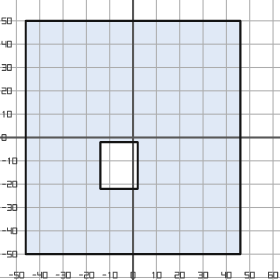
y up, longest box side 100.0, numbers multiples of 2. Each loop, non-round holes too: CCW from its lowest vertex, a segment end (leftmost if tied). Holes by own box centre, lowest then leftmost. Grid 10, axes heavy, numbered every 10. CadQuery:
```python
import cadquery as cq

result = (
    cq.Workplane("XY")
    .moveTo(-46.0, -50.0)
    .lineTo(46.0, -50.0)
    .lineTo(46.0, 50.0)
    .lineTo(-46.0, 50.0)
    .close()
    .moveTo(-14.0, -22.0)
    .lineTo(2.0, -22.0)
    .lineTo(2.0, -2.0)
    .lineTo(-14.0, -2.0)
    .close()
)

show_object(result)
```